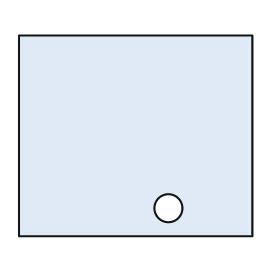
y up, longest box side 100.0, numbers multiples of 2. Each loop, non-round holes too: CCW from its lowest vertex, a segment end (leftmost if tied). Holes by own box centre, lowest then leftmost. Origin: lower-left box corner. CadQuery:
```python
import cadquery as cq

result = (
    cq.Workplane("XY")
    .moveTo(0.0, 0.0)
    .lineTo(100.0, 0.0)
    .lineTo(100.0, 86.0)
    .lineTo(0.0, 86.0)
    .close()
    .moveTo(64.0, 12.0)
    .circle(6.0)
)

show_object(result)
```